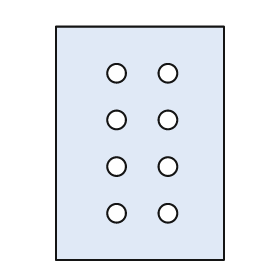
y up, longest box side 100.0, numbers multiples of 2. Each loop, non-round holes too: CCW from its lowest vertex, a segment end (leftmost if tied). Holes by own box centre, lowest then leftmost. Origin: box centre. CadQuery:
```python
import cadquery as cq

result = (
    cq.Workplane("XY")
    .moveTo(-36.0, -50.0)
    .lineTo(36.0, -50.0)
    .lineTo(36.0, 50.0)
    .lineTo(-36.0, 50.0)
    .close()
    .moveTo(-10.0, -30.0)
    .circle(4.0)
    .moveTo(12.0, -30.0)
    .circle(4.0)
    .moveTo(-10.0, -10.0)
    .circle(4.0)
    .moveTo(12.0, -10.0)
    .circle(4.0)
    .moveTo(-10.0, 10.0)
    .circle(4.0)
    .moveTo(12.0, 10.0)
    .circle(4.0)
    .moveTo(-10.0, 30.0)
    .circle(4.0)
    .moveTo(12.0, 30.0)
    .circle(4.0)
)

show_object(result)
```